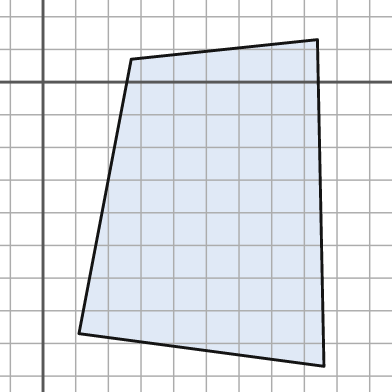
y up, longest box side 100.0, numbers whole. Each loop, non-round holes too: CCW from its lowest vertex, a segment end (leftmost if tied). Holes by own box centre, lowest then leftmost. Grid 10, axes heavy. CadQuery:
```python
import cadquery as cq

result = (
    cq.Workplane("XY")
    .moveTo(86.0, -87.0)
    .lineTo(84.0, 13.0)
    .lineTo(27.0, 7.0)
    .lineTo(11.0, -77.0)
    .close()
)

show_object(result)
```